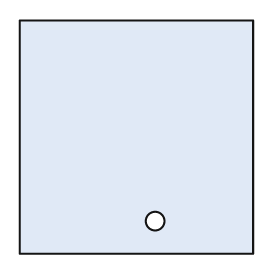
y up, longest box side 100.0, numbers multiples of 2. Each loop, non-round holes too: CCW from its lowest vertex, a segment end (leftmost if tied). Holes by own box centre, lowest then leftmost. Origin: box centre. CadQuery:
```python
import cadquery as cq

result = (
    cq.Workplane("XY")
    .moveTo(-50.0, -50.0)
    .lineTo(50.0, -50.0)
    .lineTo(50.0, 50.0)
    .lineTo(-50.0, 50.0)
    .close()
    .moveTo(8.0, -36.0)
    .circle(4.0)
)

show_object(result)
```